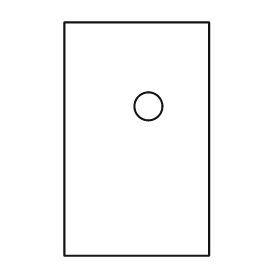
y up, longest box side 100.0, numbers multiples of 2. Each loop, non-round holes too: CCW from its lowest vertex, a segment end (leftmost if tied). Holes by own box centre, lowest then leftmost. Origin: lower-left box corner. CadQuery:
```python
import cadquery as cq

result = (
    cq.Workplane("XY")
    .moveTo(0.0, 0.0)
    .lineTo(62.0, 0.0)
    .lineTo(62.0, 100.0)
    .lineTo(0.0, 100.0)
    .close()
    .moveTo(36.0, 64.0)
    .circle(6.0)
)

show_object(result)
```